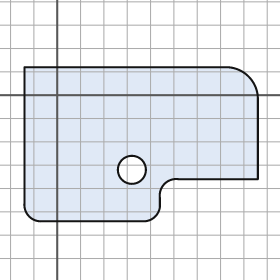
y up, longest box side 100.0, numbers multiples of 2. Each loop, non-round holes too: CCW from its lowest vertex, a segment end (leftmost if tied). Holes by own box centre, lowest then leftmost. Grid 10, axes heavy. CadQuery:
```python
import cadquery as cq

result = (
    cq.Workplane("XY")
    .moveTo(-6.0, -54.0)
    .lineTo(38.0, -54.0)
    .threePointArc((42.0, -52.0), (44.0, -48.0))
    .lineTo(44.0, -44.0)
    .threePointArc((46.0, -38.0), (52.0, -36.0))
    .lineTo(86.0, -36.0)
    .lineTo(86.0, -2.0)
    .threePointArc((82.0, 8.0), (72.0, 12.0))
    .lineTo(-14.0, 12.0)
    .lineTo(-14.0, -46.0)
    .threePointArc((-12.0, -52.0), (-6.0, -54.0))
    .close()
    .moveTo(32.0, -32.0)
    .circle(6.0)
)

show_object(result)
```